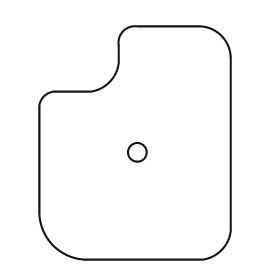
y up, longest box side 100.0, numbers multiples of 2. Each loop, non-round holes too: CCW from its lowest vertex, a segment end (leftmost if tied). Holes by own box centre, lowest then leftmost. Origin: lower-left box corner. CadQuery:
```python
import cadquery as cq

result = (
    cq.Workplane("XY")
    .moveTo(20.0, 0.0)
    .lineTo(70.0, 0.0)
    .threePointArc((78.0, 4.0), (82.0, 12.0))
    .lineTo(82.0, 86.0)
    .threePointArc((78.0, 96.0), (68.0, 100.0))
    .lineTo(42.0, 100.0)
    .threePointArc((36.0, 98.0), (34.0, 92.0))
    .lineTo(34.0, 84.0)
    .threePointArc((30.0, 76.0), (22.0, 72.0))
    .lineTo(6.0, 72.0)
    .threePointArc((2.0, 70.0), (0.0, 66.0))
    .lineTo(0.0, 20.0)
    .threePointArc((6.0, 6.0), (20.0, 0.0))
    .close()
    .moveTo(42.0, 46.0)
    .circle(4.0)
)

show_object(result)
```